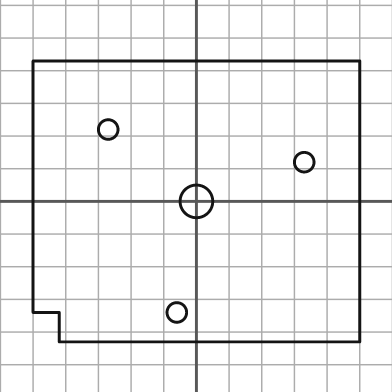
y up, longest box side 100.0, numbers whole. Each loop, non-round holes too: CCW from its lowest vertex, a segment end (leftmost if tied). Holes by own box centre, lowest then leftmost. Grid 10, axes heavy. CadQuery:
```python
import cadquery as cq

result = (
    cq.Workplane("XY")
    .moveTo(-42.0, -43.0)
    .lineTo(50.0, -43.0)
    .lineTo(50.0, 43.0)
    .lineTo(-50.0, 43.0)
    .lineTo(-50.0, -34.0)
    .lineTo(-42.0, -34.0)
    .close()
    .moveTo(-6.0, -34.0)
    .circle(3.0)
    .moveTo(0.0, 0.0)
    .circle(5.0)
    .moveTo(33.0, 12.0)
    .circle(3.0)
    .moveTo(-27.0, 22.0)
    .circle(3.0)
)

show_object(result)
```